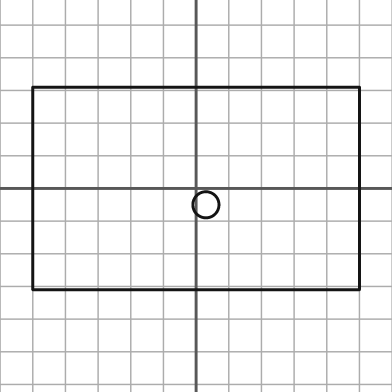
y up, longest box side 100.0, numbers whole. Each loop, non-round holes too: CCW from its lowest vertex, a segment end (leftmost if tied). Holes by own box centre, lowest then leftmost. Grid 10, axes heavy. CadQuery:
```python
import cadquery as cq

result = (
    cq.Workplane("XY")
    .moveTo(-50.0, -31.0)
    .lineTo(50.0, -31.0)
    .lineTo(50.0, 31.0)
    .lineTo(-50.0, 31.0)
    .close()
    .moveTo(3.0, -5.0)
    .circle(4.0)
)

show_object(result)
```